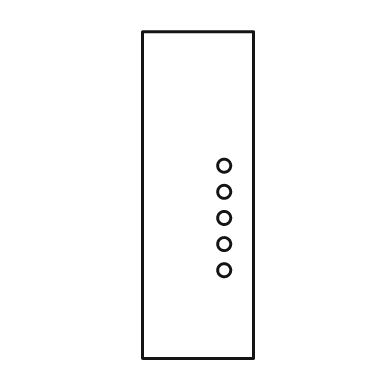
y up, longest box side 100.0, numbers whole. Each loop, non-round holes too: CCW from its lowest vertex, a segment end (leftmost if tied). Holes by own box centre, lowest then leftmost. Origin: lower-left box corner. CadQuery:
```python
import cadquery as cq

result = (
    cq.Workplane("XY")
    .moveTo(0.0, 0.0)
    .lineTo(34.0, 0.0)
    .lineTo(34.0, 100.0)
    .lineTo(0.0, 100.0)
    .close()
    .moveTo(25.0, 27.0)
    .circle(2.0)
    .moveTo(25.0, 35.0)
    .circle(2.0)
    .moveTo(25.0, 43.0)
    .circle(2.0)
    .moveTo(25.0, 51.0)
    .circle(2.0)
    .moveTo(25.0, 59.0)
    .circle(2.0)
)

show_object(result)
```